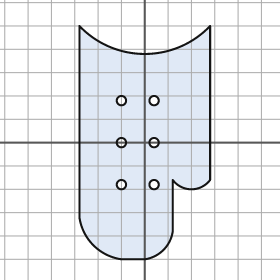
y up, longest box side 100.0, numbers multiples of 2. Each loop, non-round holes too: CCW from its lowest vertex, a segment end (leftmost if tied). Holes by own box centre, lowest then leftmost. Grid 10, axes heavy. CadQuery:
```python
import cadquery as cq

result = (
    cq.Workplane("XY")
    .moveTo(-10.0, -50.0)
    .lineTo(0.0, -50.0)
    .threePointArc((8.0, -46.0), (12.0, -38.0))
    .lineTo(12.0, -16.0)
    .threePointArc((20.0, -20.0), (28.0, -16.0))
    .lineTo(28.0, 50.0)
    .threePointArc((0.0, 38.0), (-28.0, 50.0))
    .lineTo(-28.0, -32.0)
    .threePointArc((-22.0, -44.0), (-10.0, -50.0))
    .close()
    .moveTo(-10.0, -18.0)
    .circle(2.0)
    .moveTo(4.0, -18.0)
    .circle(2.0)
    .moveTo(-10.0, 0.0)
    .circle(2.0)
    .moveTo(4.0, 0.0)
    .circle(2.0)
    .moveTo(-10.0, 18.0)
    .circle(2.0)
    .moveTo(4.0, 18.0)
    .circle(2.0)
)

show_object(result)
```